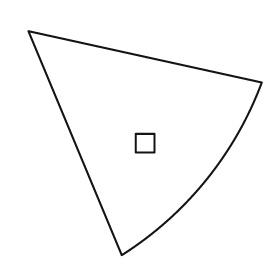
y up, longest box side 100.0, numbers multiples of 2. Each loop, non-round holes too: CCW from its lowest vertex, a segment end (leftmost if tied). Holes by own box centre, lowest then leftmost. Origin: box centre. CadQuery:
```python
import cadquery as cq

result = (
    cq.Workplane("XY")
    .moveTo(-10.0, -48.0)
    .threePointArc((26.0, -16.0), (50.0, 26.0))
    .lineTo(-50.0, 48.0)
    .close()
    .moveTo(-4.0, -4.0)
    .lineTo(4.0, -4.0)
    .lineTo(4.0, 4.0)
    .lineTo(-4.0, 4.0)
    .close()
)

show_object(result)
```